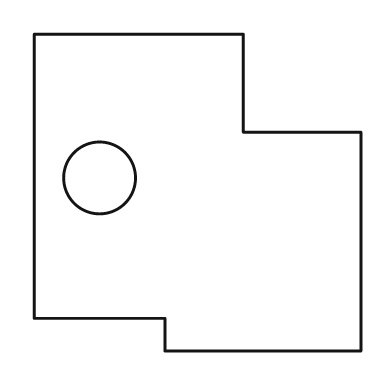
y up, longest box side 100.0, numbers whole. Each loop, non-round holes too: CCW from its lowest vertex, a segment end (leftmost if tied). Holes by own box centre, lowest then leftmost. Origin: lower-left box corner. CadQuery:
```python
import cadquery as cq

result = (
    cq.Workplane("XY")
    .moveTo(40.0, 0.0)
    .lineTo(100.0, 0.0)
    .lineTo(100.0, 67.0)
    .lineTo(64.0, 67.0)
    .lineTo(64.0, 97.0)
    .lineTo(0.0, 97.0)
    .lineTo(0.0, 10.0)
    .lineTo(40.0, 10.0)
    .close()
    .moveTo(20.0, 53.0)
    .circle(11.0)
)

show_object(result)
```